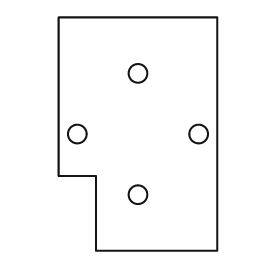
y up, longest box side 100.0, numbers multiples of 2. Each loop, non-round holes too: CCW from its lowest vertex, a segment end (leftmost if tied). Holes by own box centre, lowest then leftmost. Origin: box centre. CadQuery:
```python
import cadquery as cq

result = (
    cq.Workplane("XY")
    .moveTo(-18.0, -50.0)
    .lineTo(34.0, -50.0)
    .lineTo(34.0, 50.0)
    .lineTo(-34.0, 50.0)
    .lineTo(-34.0, -18.0)
    .lineTo(-18.0, -18.0)
    .close()
    .moveTo(0.0, -26.0)
    .circle(4.0)
    .moveTo(-26.0, 0.0)
    .circle(4.0)
    .moveTo(26.0, 0.0)
    .circle(4.0)
    .moveTo(0.0, 26.0)
    .circle(4.0)
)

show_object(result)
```